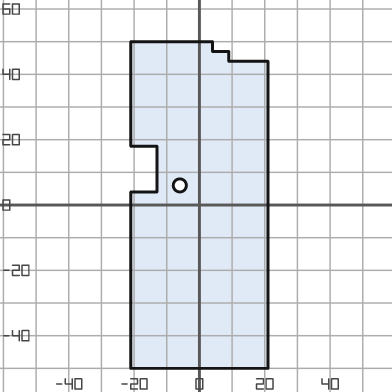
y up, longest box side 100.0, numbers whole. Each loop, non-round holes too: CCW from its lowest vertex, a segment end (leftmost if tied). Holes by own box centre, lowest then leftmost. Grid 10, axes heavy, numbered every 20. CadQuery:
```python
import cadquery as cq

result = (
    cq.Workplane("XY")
    .moveTo(-21.0, -50.0)
    .lineTo(21.0, -50.0)
    .lineTo(21.0, 44.0)
    .lineTo(9.0, 44.0)
    .lineTo(9.0, 47.0)
    .lineTo(4.0, 47.0)
    .lineTo(4.0, 50.0)
    .lineTo(-21.0, 50.0)
    .lineTo(-21.0, 18.0)
    .lineTo(-13.0, 18.0)
    .lineTo(-13.0, 4.0)
    .lineTo(-21.0, 4.0)
    .close()
    .moveTo(-6.0, 6.0)
    .circle(2.0)
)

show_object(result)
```